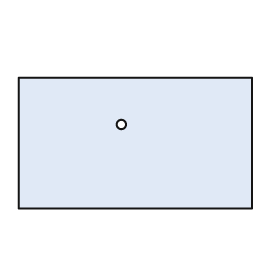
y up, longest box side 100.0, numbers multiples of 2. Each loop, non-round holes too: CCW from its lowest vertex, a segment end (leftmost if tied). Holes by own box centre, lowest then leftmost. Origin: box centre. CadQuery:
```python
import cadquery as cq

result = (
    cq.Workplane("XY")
    .moveTo(-50.0, -28.0)
    .lineTo(50.0, -28.0)
    .lineTo(50.0, 28.0)
    .lineTo(-50.0, 28.0)
    .close()
    .moveTo(-6.0, 8.0)
    .circle(2.0)
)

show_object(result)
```